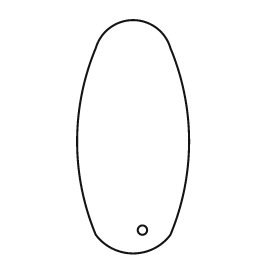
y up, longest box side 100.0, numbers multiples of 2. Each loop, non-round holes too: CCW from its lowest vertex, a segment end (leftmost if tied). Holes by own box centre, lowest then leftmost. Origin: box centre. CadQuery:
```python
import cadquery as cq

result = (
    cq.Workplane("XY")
    .moveTo(-16.0, -42.0)
    .threePointArc((0.0, -50.0), (16.0, -42.0))
    .threePointArc((24.0, -2.0), (16.0, 38.0))
    .threePointArc((0.0, 50.0), (-16.0, 38.0))
    .threePointArc((-24.0, -2.0), (-16.0, -42.0))
    .close()
    .moveTo(4.0, -40.0)
    .circle(2.0)
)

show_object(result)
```